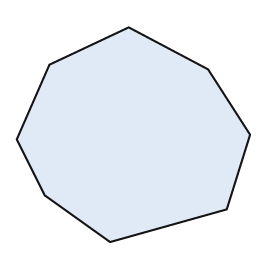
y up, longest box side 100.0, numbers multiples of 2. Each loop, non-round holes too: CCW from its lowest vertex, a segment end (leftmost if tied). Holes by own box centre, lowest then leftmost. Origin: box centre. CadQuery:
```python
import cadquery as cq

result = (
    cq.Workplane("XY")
    .moveTo(-10.0, -46.0)
    .lineTo(40.0, -32.0)
    .lineTo(50.0, 0.0)
    .lineTo(32.0, 28.0)
    .lineTo(-2.0, 46.0)
    .lineTo(-36.0, 30.0)
    .lineTo(-50.0, -2.0)
    .lineTo(-38.0, -26.0)
    .close()
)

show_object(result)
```